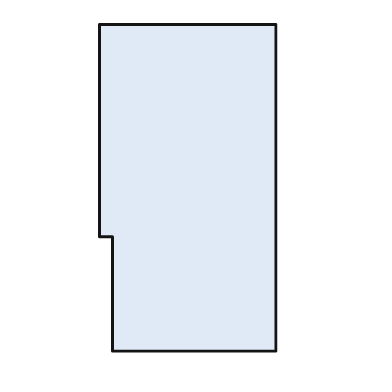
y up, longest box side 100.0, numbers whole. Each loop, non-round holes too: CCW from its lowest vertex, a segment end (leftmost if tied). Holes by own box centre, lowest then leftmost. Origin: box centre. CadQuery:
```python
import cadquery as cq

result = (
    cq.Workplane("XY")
    .moveTo(-23.0, -50.0)
    .lineTo(27.0, -50.0)
    .lineTo(27.0, 50.0)
    .lineTo(-27.0, 50.0)
    .lineTo(-27.0, -15.0)
    .lineTo(-23.0, -15.0)
    .close()
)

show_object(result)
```